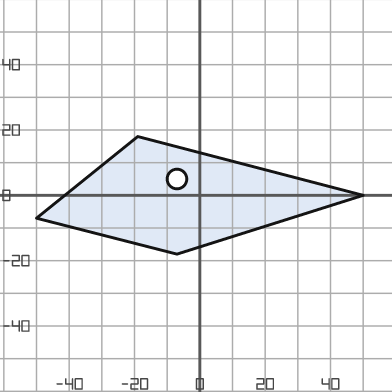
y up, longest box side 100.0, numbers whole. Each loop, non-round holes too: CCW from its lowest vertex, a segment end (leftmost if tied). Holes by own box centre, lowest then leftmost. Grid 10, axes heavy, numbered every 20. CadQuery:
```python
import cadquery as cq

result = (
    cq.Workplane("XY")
    .moveTo(-7.0, -18.0)
    .lineTo(50.0, 0.0)
    .lineTo(-19.0, 18.0)
    .lineTo(-50.0, -7.0)
    .close()
    .moveTo(-7.0, 5.0)
    .circle(3.0)
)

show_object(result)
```